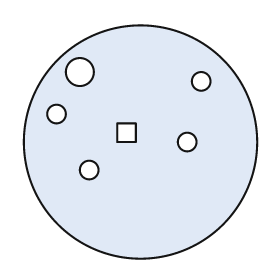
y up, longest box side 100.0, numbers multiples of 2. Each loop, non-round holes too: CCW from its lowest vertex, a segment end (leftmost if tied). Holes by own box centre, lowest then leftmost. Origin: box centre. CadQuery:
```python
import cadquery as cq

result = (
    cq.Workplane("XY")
    .moveTo(0.0, 0.0)
    .circle(50.0)
    .moveTo(-22.0, -12.0)
    .circle(4.0)
    .moveTo(20.0, 0.0)
    .circle(4.0)
    .moveTo(-10.0, 0.0)
    .lineTo(-2.0, 0.0)
    .lineTo(-2.0, 8.0)
    .lineTo(-10.0, 8.0)
    .close()
    .moveTo(-36.0, 12.0)
    .circle(4.0)
    .moveTo(26.0, 26.0)
    .circle(4.0)
    .moveTo(-26.0, 30.0)
    .circle(6.0)
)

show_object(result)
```